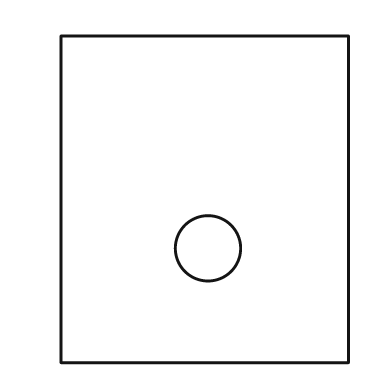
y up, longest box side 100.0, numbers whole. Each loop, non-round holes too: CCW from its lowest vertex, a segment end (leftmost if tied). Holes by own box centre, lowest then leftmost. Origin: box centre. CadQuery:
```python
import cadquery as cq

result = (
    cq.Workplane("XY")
    .moveTo(-44.0, -50.0)
    .lineTo(44.0, -50.0)
    .lineTo(44.0, 50.0)
    .lineTo(-44.0, 50.0)
    .close()
    .moveTo(1.0, -15.0)
    .circle(10.0)
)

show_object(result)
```